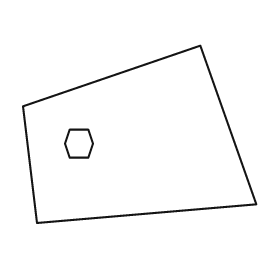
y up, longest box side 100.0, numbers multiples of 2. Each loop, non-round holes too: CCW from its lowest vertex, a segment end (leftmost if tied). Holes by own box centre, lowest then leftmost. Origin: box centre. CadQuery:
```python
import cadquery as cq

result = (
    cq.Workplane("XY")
    .moveTo(-44.0, -38.0)
    .lineTo(50.0, -30.0)
    .lineTo(26.0, 38.0)
    .lineTo(-50.0, 12.0)
    .close()
    .moveTo(-30.0, -10.0)
    .lineTo(-22.0, -10.0)
    .lineTo(-20.0, -4.0)
    .lineTo(-22.0, 2.0)
    .lineTo(-30.0, 2.0)
    .lineTo(-32.0, -4.0)
    .close()
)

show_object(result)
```